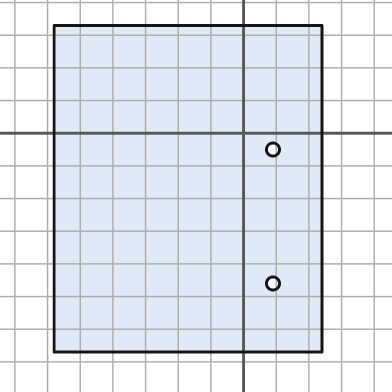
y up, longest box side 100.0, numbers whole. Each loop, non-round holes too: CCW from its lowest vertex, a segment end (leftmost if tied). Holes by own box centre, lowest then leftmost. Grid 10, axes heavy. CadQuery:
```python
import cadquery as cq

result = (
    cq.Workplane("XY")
    .moveTo(-58.0, -67.0)
    .lineTo(24.0, -67.0)
    .lineTo(24.0, 33.0)
    .lineTo(-58.0, 33.0)
    .close()
    .moveTo(9.0, -46.0)
    .circle(2.0)
    .moveTo(9.0, -5.0)
    .circle(2.0)
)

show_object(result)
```